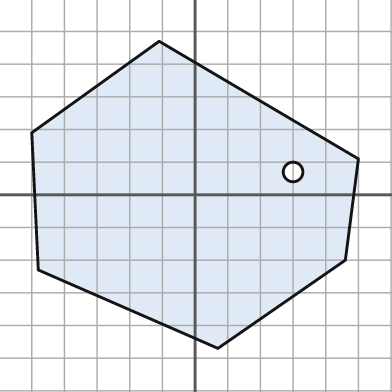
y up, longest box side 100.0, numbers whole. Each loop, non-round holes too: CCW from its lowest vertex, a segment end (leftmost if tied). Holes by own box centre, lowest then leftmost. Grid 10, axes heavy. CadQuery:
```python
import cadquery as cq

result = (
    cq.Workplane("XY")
    .moveTo(7.0, -47.0)
    .lineTo(46.0, -20.0)
    .lineTo(50.0, 11.0)
    .lineTo(-11.0, 47.0)
    .lineTo(-50.0, 19.0)
    .lineTo(-48.0, -23.0)
    .close()
    .moveTo(30.0, 7.0)
    .circle(3.0)
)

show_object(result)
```